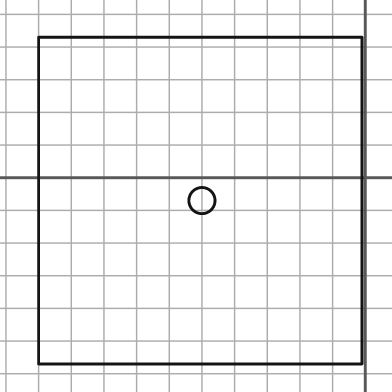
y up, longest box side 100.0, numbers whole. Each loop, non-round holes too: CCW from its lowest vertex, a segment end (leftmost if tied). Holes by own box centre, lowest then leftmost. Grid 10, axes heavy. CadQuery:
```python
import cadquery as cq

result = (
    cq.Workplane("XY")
    .moveTo(-100.0, -57.0)
    .lineTo(-1.0, -57.0)
    .lineTo(-1.0, 43.0)
    .lineTo(-100.0, 43.0)
    .close()
    .moveTo(-50.0, -7.0)
    .circle(4.0)
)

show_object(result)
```